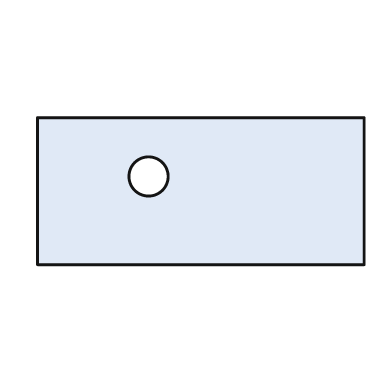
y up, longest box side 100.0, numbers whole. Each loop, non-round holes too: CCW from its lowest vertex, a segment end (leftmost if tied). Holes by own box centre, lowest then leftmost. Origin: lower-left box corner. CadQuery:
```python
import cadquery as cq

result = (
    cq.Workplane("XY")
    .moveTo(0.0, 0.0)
    .lineTo(100.0, 0.0)
    .lineTo(100.0, 45.0)
    .lineTo(0.0, 45.0)
    .close()
    .moveTo(34.0, 27.0)
    .circle(6.0)
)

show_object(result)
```